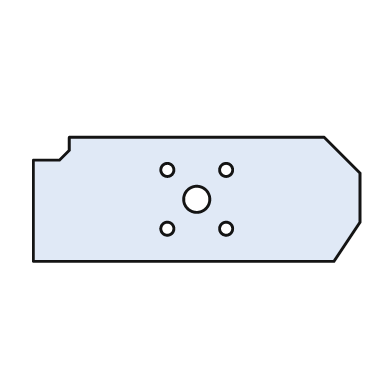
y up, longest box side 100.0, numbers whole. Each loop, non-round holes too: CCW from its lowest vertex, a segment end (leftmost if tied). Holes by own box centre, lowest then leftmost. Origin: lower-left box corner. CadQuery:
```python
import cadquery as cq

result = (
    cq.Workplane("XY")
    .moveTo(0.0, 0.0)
    .lineTo(92.0, 0.0)
    .lineTo(100.0, 12.0)
    .lineTo(100.0, 27.0)
    .lineTo(89.0, 38.0)
    .lineTo(11.0, 38.0)
    .lineTo(11.0, 34.0)
    .lineTo(8.0, 31.0)
    .lineTo(0.0, 31.0)
    .close()
    .moveTo(41.0, 10.0)
    .circle(2.0)
    .moveTo(59.0, 10.0)
    .circle(2.0)
    .moveTo(50.0, 19.0)
    .circle(4.0)
    .moveTo(41.0, 28.0)
    .circle(2.0)
    .moveTo(59.0, 28.0)
    .circle(2.0)
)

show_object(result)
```